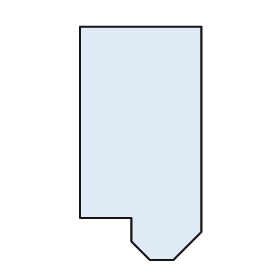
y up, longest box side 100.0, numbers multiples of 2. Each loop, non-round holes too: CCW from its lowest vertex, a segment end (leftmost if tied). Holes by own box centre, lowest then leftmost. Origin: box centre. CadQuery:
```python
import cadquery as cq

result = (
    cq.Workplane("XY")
    .moveTo(4.0, -50.0)
    .lineTo(14.0, -50.0)
    .lineTo(26.0, -38.0)
    .lineTo(26.0, 50.0)
    .lineTo(-26.0, 50.0)
    .lineTo(-26.0, -32.0)
    .lineTo(-4.0, -32.0)
    .lineTo(-4.0, -42.0)
    .close()
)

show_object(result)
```